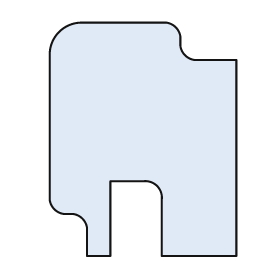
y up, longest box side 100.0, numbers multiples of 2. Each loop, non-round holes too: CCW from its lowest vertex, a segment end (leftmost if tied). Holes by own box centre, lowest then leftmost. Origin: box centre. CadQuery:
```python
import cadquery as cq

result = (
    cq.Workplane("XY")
    .moveTo(-24.0, -50.0)
    .lineTo(-14.0, -50.0)
    .lineTo(-14.0, -18.0)
    .lineTo(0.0, -18.0)
    .threePointArc((6.0, -20.0), (8.0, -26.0))
    .lineTo(8.0, -50.0)
    .lineTo(40.0, -50.0)
    .lineTo(40.0, 34.0)
    .lineTo(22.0, 34.0)
    .threePointArc((18.0, 36.0), (16.0, 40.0))
    .lineTo(16.0, 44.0)
    .threePointArc((14.0, 48.0), (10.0, 50.0))
    .lineTo(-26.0, 50.0)
    .threePointArc((-36.0, 46.0), (-40.0, 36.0))
    .lineTo(-40.0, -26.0)
    .threePointArc((-38.0, -30.0), (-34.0, -32.0))
    .lineTo(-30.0, -32.0)
    .threePointArc((-26.0, -34.0), (-24.0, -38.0))
    .close()
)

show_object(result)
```